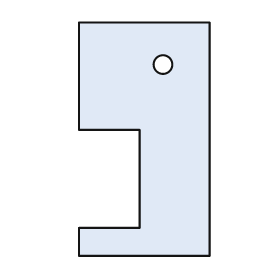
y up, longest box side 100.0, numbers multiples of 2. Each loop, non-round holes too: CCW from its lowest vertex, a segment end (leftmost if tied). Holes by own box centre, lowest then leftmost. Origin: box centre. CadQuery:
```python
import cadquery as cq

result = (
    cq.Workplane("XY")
    .moveTo(-28.0, -50.0)
    .lineTo(28.0, -50.0)
    .lineTo(28.0, 50.0)
    .lineTo(-28.0, 50.0)
    .lineTo(-28.0, 4.0)
    .lineTo(-2.0, 4.0)
    .lineTo(-2.0, -38.0)
    .lineTo(-28.0, -38.0)
    .close()
    .moveTo(8.0, 32.0)
    .circle(4.0)
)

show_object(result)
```